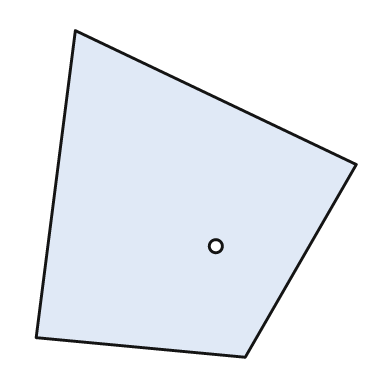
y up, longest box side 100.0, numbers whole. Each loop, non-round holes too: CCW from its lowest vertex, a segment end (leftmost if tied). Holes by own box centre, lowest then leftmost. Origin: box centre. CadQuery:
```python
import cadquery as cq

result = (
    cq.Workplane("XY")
    .moveTo(15.0, -50.0)
    .lineTo(49.0, 9.0)
    .lineTo(-37.0, 50.0)
    .lineTo(-49.0, -44.0)
    .close()
    .moveTo(6.0, -16.0)
    .circle(2.0)
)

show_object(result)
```